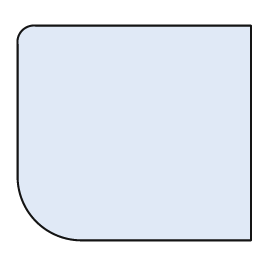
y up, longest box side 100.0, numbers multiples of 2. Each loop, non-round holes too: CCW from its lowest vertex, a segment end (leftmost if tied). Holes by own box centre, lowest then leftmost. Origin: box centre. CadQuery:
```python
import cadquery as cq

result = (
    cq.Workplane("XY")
    .moveTo(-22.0, -46.0)
    .lineTo(50.0, -46.0)
    .lineTo(50.0, 46.0)
    .lineTo(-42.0, 46.0)
    .threePointArc((-48.0, 44.0), (-50.0, 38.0))
    .lineTo(-50.0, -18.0)
    .threePointArc((-42.0, -38.0), (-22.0, -46.0))
    .close()
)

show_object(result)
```